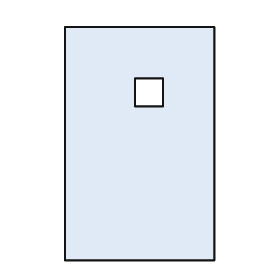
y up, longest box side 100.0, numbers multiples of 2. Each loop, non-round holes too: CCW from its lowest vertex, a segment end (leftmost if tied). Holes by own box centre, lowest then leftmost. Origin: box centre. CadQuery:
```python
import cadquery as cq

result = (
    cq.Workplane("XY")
    .moveTo(-32.0, -50.0)
    .lineTo(32.0, -50.0)
    .lineTo(32.0, 50.0)
    .lineTo(-32.0, 50.0)
    .close()
    .moveTo(-2.0, 16.0)
    .lineTo(10.0, 16.0)
    .lineTo(10.0, 28.0)
    .lineTo(-2.0, 28.0)
    .close()
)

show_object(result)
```